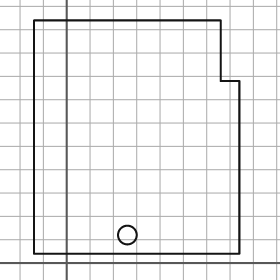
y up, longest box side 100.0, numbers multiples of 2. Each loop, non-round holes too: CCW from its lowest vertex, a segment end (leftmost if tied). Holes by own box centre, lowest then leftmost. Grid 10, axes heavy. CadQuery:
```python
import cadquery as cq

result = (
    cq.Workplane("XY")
    .moveTo(-14.0, 4.0)
    .lineTo(74.0, 4.0)
    .lineTo(74.0, 78.0)
    .lineTo(66.0, 78.0)
    .lineTo(66.0, 104.0)
    .lineTo(-14.0, 104.0)
    .close()
    .moveTo(26.0, 12.0)
    .circle(4.0)
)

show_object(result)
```